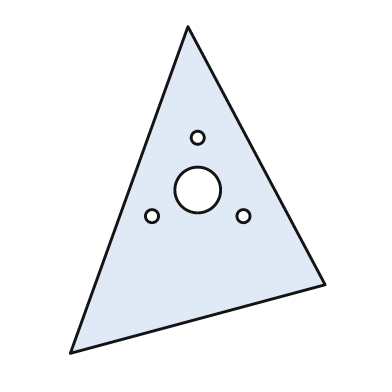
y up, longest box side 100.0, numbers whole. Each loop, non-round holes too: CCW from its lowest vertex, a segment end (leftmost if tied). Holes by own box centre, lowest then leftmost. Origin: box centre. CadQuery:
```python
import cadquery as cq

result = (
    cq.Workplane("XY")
    .moveTo(-39.0, -50.0)
    .lineTo(39.0, -29.0)
    .lineTo(-3.0, 50.0)
    .close()
    .moveTo(-14.0, -8.0)
    .circle(2.0)
    .moveTo(14.0, -8.0)
    .circle(2.0)
    .moveTo(0.0, 0.0)
    .circle(7.0)
    .moveTo(0.0, 16.0)
    .circle(2.0)
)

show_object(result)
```